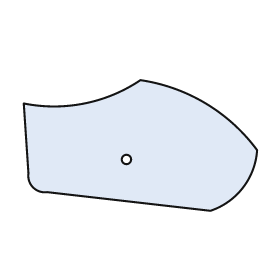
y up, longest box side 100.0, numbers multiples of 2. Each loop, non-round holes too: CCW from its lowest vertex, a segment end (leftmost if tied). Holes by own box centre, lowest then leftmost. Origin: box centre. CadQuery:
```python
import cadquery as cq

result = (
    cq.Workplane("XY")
    .moveTo(30.0, -28.0)
    .threePointArc((44.0, -18.0), (50.0, -2.0))
    .threePointArc((28.0, 18.0), (0.0, 28.0))
    .threePointArc((-24.0, 18.0), (-50.0, 18.0))
    .lineTo(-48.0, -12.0)
    .threePointArc((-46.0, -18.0), (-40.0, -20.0))
    .close()
    .moveTo(-6.0, -6.0)
    .circle(2.0)
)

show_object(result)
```